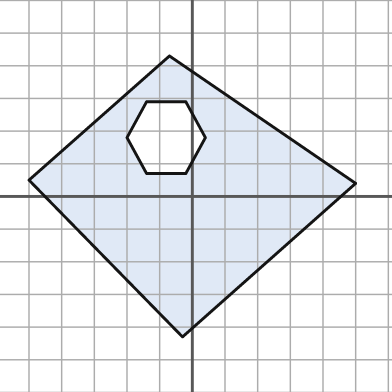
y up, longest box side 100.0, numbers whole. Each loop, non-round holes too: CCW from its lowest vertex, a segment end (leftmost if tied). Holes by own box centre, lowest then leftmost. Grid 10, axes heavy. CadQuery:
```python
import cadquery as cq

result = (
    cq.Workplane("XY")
    .moveTo(-3.0, -43.0)
    .lineTo(50.0, 4.0)
    .lineTo(-7.0, 43.0)
    .lineTo(-50.0, 5.0)
    .close()
    .moveTo(-14.0, 7.0)
    .lineTo(-2.0, 7.0)
    .lineTo(4.0, 18.0)
    .lineTo(-2.0, 29.0)
    .lineTo(-14.0, 29.0)
    .lineTo(-20.0, 18.0)
    .close()
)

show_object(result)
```